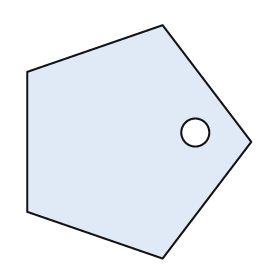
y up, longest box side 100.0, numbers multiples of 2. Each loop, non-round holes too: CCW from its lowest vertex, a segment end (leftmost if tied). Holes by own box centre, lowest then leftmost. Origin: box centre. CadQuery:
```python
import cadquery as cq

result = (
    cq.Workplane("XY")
    .moveTo(10.0, -50.0)
    .lineTo(48.0, 0.0)
    .lineTo(10.0, 50.0)
    .lineTo(-48.0, 30.0)
    .lineTo(-48.0, -30.0)
    .close()
    .moveTo(24.0, 4.0)
    .circle(6.0)
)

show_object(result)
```